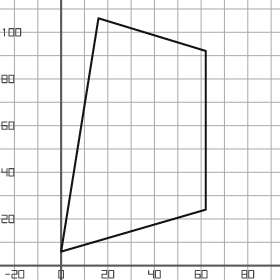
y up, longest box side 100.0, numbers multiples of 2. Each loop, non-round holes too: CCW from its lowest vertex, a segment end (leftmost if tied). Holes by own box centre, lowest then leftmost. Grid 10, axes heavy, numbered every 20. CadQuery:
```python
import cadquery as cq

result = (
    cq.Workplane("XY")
    .moveTo(0.0, 6.0)
    .lineTo(62.0, 24.0)
    .lineTo(62.0, 92.0)
    .lineTo(16.0, 106.0)
    .close()
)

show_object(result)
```